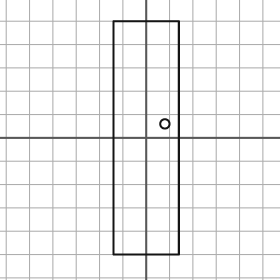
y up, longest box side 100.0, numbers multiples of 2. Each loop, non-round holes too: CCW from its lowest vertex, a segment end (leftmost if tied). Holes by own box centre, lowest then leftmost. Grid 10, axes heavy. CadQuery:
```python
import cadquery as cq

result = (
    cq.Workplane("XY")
    .moveTo(-14.0, -50.0)
    .lineTo(14.0, -50.0)
    .lineTo(14.0, 50.0)
    .lineTo(-14.0, 50.0)
    .close()
    .moveTo(8.0, 6.0)
    .circle(2.0)
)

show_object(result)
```